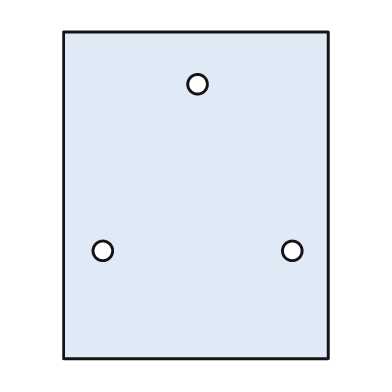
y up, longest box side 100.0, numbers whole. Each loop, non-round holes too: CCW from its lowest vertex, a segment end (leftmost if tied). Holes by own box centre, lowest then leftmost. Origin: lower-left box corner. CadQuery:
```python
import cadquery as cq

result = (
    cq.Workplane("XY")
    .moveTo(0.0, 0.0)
    .lineTo(81.0, 0.0)
    .lineTo(81.0, 100.0)
    .lineTo(0.0, 100.0)
    .close()
    .moveTo(12.0, 33.0)
    .circle(3.0)
    .moveTo(70.0, 33.0)
    .circle(3.0)
    .moveTo(41.0, 84.0)
    .circle(3.0)
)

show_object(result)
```